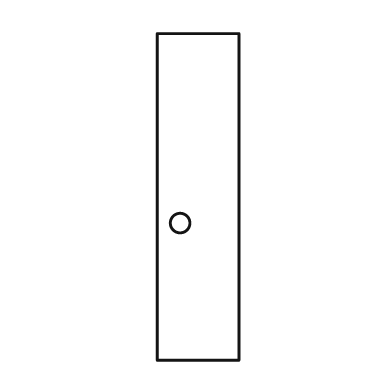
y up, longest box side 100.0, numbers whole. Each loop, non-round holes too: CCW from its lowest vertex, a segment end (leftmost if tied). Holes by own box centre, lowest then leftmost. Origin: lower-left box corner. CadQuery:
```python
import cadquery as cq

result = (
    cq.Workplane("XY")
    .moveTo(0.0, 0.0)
    .lineTo(25.0, 0.0)
    .lineTo(25.0, 100.0)
    .lineTo(0.0, 100.0)
    .close()
    .moveTo(7.0, 42.0)
    .circle(3.0)
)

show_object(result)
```